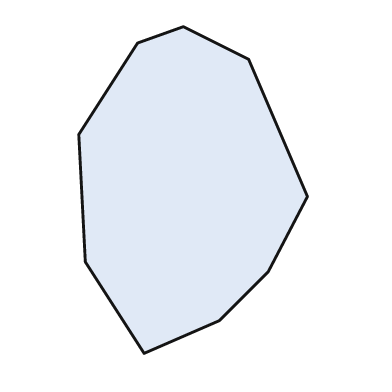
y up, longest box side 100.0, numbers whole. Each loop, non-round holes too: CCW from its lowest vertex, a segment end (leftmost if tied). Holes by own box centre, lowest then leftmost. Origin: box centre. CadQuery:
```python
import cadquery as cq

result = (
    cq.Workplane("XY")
    .moveTo(-15.0, -50.0)
    .lineTo(8.0, -40.0)
    .lineTo(23.0, -25.0)
    .lineTo(35.0, -2.0)
    .lineTo(17.0, 40.0)
    .lineTo(-3.0, 50.0)
    .lineTo(-17.0, 45.0)
    .lineTo(-35.0, 17.0)
    .lineTo(-33.0, -22.0)
    .close()
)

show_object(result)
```